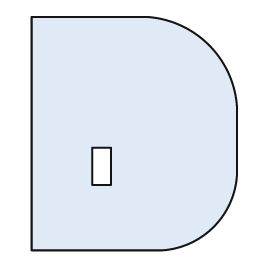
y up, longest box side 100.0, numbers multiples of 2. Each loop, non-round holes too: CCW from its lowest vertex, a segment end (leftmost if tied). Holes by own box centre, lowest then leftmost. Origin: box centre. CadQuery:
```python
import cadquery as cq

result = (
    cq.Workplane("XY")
    .moveTo(-44.0, -50.0)
    .lineTo(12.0, -50.0)
    .threePointArc((34.0, -40.0), (44.0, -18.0))
    .lineTo(44.0, 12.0)
    .threePointArc((32.0, 38.0), (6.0, 50.0))
    .lineTo(-44.0, 50.0)
    .close()
    .moveTo(-18.0, -22.0)
    .lineTo(-10.0, -22.0)
    .lineTo(-10.0, -6.0)
    .lineTo(-18.0, -6.0)
    .close()
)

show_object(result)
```